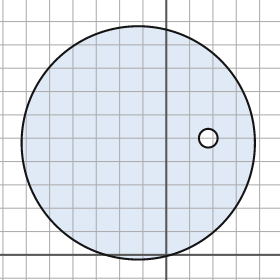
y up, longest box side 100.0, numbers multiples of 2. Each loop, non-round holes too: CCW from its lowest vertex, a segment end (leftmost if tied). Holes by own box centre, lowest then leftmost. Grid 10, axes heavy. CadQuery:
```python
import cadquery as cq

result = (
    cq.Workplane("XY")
    .moveTo(-12.0, 48.0)
    .circle(50.0)
    .moveTo(18.0, 50.0)
    .circle(4.0)
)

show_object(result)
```